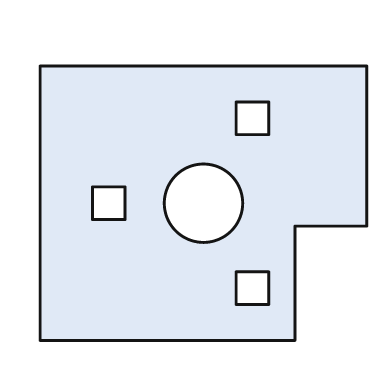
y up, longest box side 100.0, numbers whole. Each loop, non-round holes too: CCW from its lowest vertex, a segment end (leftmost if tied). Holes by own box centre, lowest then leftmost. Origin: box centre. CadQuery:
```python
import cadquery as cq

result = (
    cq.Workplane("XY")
    .moveTo(-50.0, -42.0)
    .lineTo(28.0, -42.0)
    .lineTo(28.0, -7.0)
    .lineTo(50.0, -7.0)
    .lineTo(50.0, 42.0)
    .lineTo(-50.0, 42.0)
    .close()
    .moveTo(10.0, -31.0)
    .lineTo(20.0, -31.0)
    .lineTo(20.0, -21.0)
    .lineTo(10.0, -21.0)
    .close()
    .moveTo(-34.0, -5.0)
    .lineTo(-24.0, -5.0)
    .lineTo(-24.0, 5.0)
    .lineTo(-34.0, 5.0)
    .close()
    .moveTo(0.0, 0.0)
    .circle(12.0)
    .moveTo(10.0, 21.0)
    .lineTo(20.0, 21.0)
    .lineTo(20.0, 31.0)
    .lineTo(10.0, 31.0)
    .close()
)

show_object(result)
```